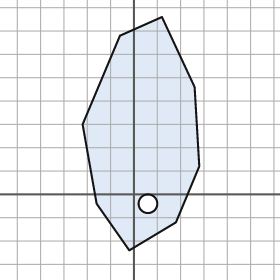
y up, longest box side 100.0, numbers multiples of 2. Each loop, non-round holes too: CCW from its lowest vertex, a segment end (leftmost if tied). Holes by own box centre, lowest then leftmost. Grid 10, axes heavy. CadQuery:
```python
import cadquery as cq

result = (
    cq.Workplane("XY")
    .moveTo(-2.0, -24.0)
    .lineTo(18.0, -12.0)
    .lineTo(28.0, 12.0)
    .lineTo(26.0, 46.0)
    .lineTo(12.0, 76.0)
    .lineTo(-6.0, 68.0)
    .lineTo(-22.0, 30.0)
    .lineTo(-16.0, -4.0)
    .close()
    .moveTo(6.0, -4.0)
    .circle(4.0)
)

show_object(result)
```